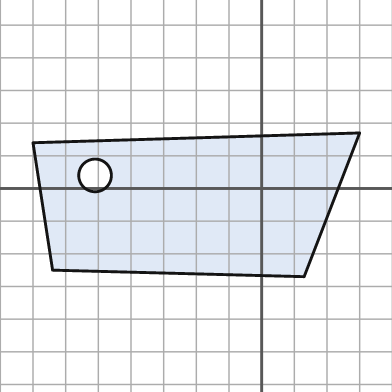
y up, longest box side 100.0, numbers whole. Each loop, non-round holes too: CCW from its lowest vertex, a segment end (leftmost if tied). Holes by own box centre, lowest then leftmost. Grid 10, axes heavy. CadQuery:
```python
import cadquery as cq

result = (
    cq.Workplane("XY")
    .moveTo(13.0, -27.0)
    .lineTo(30.0, 17.0)
    .lineTo(-70.0, 14.0)
    .lineTo(-64.0, -25.0)
    .close()
    .moveTo(-51.0, 4.0)
    .circle(5.0)
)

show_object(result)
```